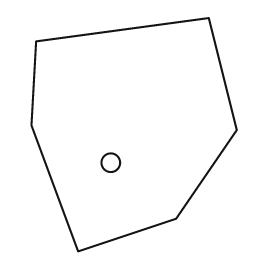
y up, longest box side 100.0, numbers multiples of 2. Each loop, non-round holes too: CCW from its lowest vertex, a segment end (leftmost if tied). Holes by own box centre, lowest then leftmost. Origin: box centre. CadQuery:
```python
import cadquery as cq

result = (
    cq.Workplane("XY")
    .moveTo(-24.0, -50.0)
    .lineTo(18.0, -36.0)
    .lineTo(44.0, 2.0)
    .lineTo(32.0, 50.0)
    .lineTo(-42.0, 40.0)
    .lineTo(-44.0, 4.0)
    .close()
    .moveTo(-10.0, -12.0)
    .circle(4.0)
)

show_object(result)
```